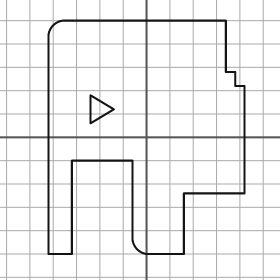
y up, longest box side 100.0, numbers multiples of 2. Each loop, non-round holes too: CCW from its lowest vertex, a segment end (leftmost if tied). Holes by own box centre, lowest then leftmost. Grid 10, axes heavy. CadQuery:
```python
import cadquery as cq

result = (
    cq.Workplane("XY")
    .moveTo(-42.0, -50.0)
    .lineTo(-32.0, -50.0)
    .lineTo(-32.0, -10.0)
    .lineTo(-6.0, -10.0)
    .lineTo(-6.0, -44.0)
    .threePointArc((-4.0, -48.0), (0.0, -50.0))
    .lineTo(16.0, -50.0)
    .lineTo(16.0, -24.0)
    .lineTo(42.0, -24.0)
    .lineTo(42.0, 22.0)
    .lineTo(38.0, 22.0)
    .lineTo(38.0, 28.0)
    .lineTo(34.0, 28.0)
    .lineTo(34.0, 50.0)
    .lineTo(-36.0, 50.0)
    .threePointArc((-40.0, 48.0), (-42.0, 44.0))
    .close()
    .moveTo(-24.0, 6.0)
    .lineTo(-14.0, 12.0)
    .lineTo(-24.0, 18.0)
    .close()
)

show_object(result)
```